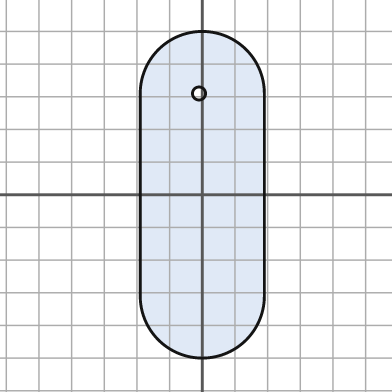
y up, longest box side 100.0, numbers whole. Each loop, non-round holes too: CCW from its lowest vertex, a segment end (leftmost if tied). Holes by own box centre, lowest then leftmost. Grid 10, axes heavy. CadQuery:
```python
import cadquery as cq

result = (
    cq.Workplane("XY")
    .moveTo(-19.0, -31.0)
    .threePointArc((0.0, -50.0), (19.0, -31.0))
    .lineTo(19.0, 31.0)
    .threePointArc((0.0, 50.0), (-19.0, 31.0))
    .close()
    .moveTo(-1.0, 31.0)
    .circle(2.0)
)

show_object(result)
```